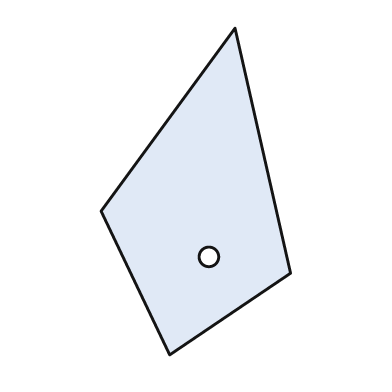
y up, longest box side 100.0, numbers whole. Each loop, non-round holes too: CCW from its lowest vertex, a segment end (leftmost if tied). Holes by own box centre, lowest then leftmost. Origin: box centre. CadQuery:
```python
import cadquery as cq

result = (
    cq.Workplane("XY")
    .moveTo(-8.0, -50.0)
    .lineTo(29.0, -25.0)
    .lineTo(12.0, 50.0)
    .lineTo(-29.0, -6.0)
    .close()
    .moveTo(4.0, -20.0)
    .circle(3.0)
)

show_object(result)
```